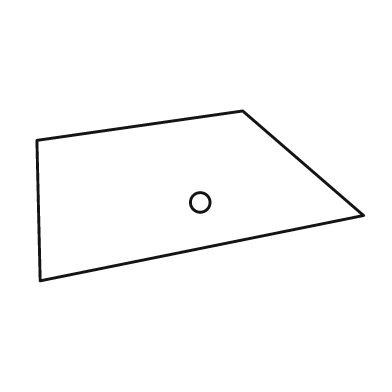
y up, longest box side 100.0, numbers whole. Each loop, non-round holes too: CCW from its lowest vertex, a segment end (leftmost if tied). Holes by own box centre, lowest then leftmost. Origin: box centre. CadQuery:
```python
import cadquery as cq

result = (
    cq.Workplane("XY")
    .moveTo(-49.0, -26.0)
    .lineTo(50.0, -6.0)
    .lineTo(13.0, 26.0)
    .lineTo(-50.0, 17.0)
    .close()
    .moveTo(0.0, -2.0)
    .circle(3.0)
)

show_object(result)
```